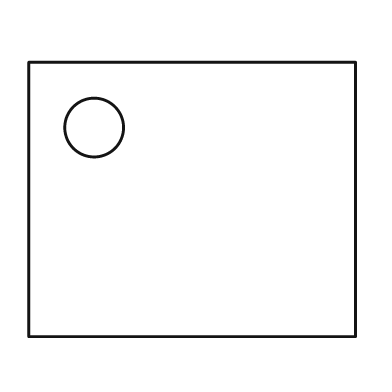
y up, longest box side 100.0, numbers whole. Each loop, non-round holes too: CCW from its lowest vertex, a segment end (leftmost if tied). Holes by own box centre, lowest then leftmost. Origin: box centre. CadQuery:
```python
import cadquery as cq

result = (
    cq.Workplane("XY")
    .moveTo(-50.0, -42.0)
    .lineTo(50.0, -42.0)
    .lineTo(50.0, 42.0)
    .lineTo(-50.0, 42.0)
    .close()
    .moveTo(-30.0, 22.0)
    .circle(9.0)
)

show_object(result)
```